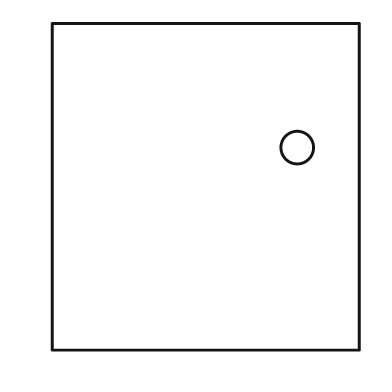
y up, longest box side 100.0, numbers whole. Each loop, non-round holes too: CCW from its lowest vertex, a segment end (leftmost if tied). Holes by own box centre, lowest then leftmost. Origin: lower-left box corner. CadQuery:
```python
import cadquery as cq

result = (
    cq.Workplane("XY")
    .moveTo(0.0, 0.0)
    .lineTo(94.0, 0.0)
    .lineTo(94.0, 100.0)
    .lineTo(0.0, 100.0)
    .close()
    .moveTo(75.0, 62.0)
    .circle(5.0)
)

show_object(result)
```